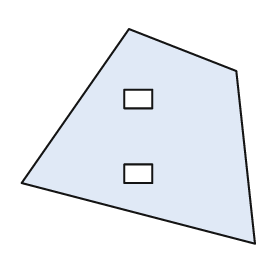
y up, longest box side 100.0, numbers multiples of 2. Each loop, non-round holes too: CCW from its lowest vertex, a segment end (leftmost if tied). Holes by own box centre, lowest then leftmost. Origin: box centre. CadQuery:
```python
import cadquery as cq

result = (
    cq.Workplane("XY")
    .moveTo(50.0, -46.0)
    .lineTo(42.0, 28.0)
    .lineTo(-4.0, 46.0)
    .lineTo(-50.0, -20.0)
    .close()
    .moveTo(-6.0, -20.0)
    .lineTo(6.0, -20.0)
    .lineTo(6.0, -12.0)
    .lineTo(-6.0, -12.0)
    .close()
    .moveTo(-6.0, 12.0)
    .lineTo(6.0, 12.0)
    .lineTo(6.0, 20.0)
    .lineTo(-6.0, 20.0)
    .close()
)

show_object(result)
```